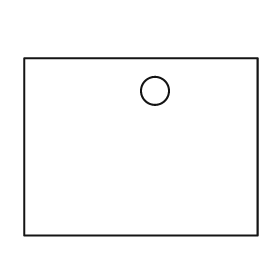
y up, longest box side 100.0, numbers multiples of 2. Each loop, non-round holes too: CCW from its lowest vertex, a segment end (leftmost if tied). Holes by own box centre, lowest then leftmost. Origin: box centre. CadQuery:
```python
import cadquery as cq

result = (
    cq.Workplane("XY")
    .moveTo(-50.0, -38.0)
    .lineTo(50.0, -38.0)
    .lineTo(50.0, 38.0)
    .lineTo(-50.0, 38.0)
    .close()
    .moveTo(6.0, 24.0)
    .circle(6.0)
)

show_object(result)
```